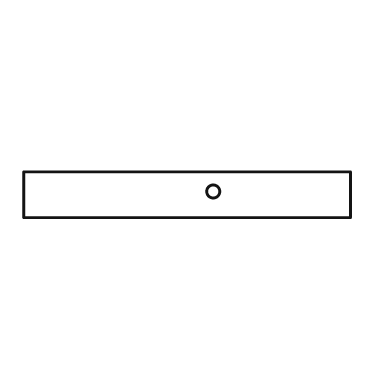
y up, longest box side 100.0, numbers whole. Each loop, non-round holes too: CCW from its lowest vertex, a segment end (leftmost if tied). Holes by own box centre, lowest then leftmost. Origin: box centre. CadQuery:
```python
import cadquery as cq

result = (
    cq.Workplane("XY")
    .moveTo(-50.0, -7.0)
    .lineTo(50.0, -7.0)
    .lineTo(50.0, 7.0)
    .lineTo(-50.0, 7.0)
    .close()
    .moveTo(8.0, 1.0)
    .circle(2.0)
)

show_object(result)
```